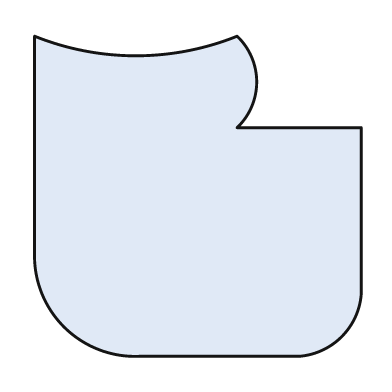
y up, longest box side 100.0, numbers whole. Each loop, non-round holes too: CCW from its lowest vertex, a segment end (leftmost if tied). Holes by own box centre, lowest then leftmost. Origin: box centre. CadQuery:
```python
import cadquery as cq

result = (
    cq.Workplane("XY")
    .moveTo(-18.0, -49.0)
    .lineTo(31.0, -49.0)
    .threePointArc((44.0, -43.0), (50.0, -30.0))
    .lineTo(50.0, 21.0)
    .lineTo(12.0, 21.0)
    .threePointArc((18.0, 35.0), (12.0, 49.0))
    .threePointArc((-19.0, 43.0), (-50.0, 49.0))
    .lineTo(-50.0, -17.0)
    .threePointArc((-41.0, -40.0), (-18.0, -49.0))
    .close()
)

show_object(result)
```